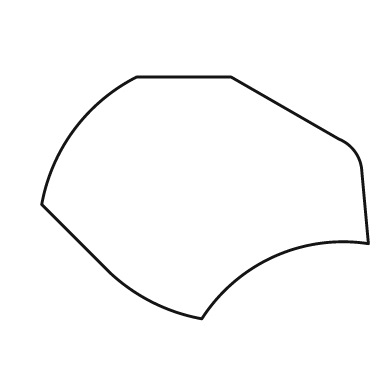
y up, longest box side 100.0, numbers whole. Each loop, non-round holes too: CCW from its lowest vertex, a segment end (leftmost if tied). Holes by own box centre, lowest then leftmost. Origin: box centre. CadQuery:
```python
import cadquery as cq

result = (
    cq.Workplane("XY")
    .moveTo(-1.0, -37.0)
    .threePointArc((21.0, -18.0), (50.0, -14.0))
    .lineTo(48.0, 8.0)
    .threePointArc((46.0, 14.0), (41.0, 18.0))
    .lineTo(8.0, 37.0)
    .lineTo(-21.0, 37.0)
    .threePointArc((-40.0, 21.0), (-50.0, -2.0))
    .lineTo(-29.0, -23.0)
    .threePointArc((-16.0, -32.0), (-1.0, -37.0))
    .close()
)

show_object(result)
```